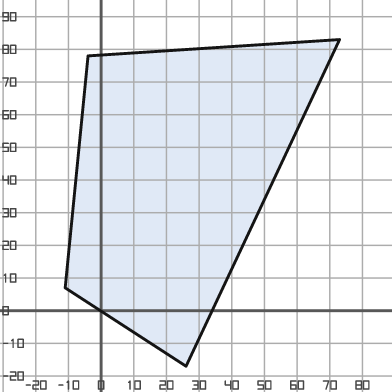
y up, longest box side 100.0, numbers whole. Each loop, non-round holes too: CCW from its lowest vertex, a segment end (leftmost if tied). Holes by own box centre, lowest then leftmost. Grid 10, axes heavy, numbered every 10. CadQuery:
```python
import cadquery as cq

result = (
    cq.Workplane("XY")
    .moveTo(26.0, -17.0)
    .lineTo(73.0, 83.0)
    .lineTo(-4.0, 78.0)
    .lineTo(-11.0, 7.0)
    .close()
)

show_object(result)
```